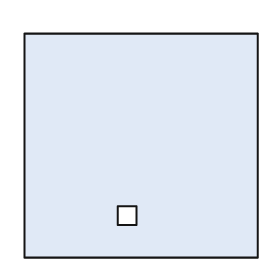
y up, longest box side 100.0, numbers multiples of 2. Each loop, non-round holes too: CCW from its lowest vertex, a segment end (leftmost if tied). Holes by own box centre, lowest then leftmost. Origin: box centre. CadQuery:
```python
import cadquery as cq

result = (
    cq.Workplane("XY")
    .moveTo(-50.0, -48.0)
    .lineTo(50.0, -48.0)
    .lineTo(50.0, 48.0)
    .lineTo(-50.0, 48.0)
    .close()
    .moveTo(-10.0, -34.0)
    .lineTo(-2.0, -34.0)
    .lineTo(-2.0, -26.0)
    .lineTo(-10.0, -26.0)
    .close()
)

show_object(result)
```